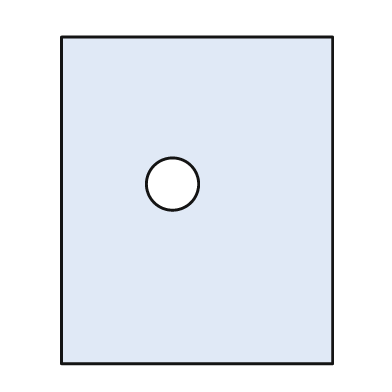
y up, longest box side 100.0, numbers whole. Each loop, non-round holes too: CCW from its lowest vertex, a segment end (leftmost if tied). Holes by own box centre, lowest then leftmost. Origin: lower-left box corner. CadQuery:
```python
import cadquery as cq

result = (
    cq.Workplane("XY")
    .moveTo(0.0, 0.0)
    .lineTo(83.0, 0.0)
    .lineTo(83.0, 100.0)
    .lineTo(0.0, 100.0)
    .close()
    .moveTo(34.0, 55.0)
    .circle(8.0)
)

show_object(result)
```